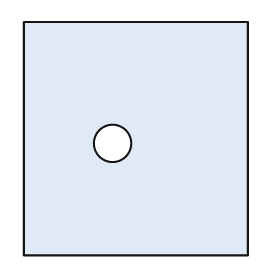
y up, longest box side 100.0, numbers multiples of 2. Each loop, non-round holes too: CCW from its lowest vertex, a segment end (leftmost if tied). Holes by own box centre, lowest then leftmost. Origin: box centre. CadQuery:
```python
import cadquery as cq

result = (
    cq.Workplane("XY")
    .moveTo(-48.0, -50.0)
    .lineTo(48.0, -50.0)
    .lineTo(48.0, 50.0)
    .lineTo(-48.0, 50.0)
    .close()
    .moveTo(-10.0, -2.0)
    .circle(8.0)
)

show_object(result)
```